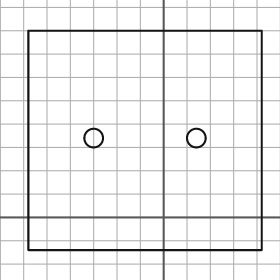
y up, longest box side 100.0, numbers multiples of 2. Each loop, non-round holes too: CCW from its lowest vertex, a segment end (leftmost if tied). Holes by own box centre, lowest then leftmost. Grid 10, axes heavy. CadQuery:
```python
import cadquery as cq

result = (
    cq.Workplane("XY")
    .moveTo(-58.0, -14.0)
    .lineTo(42.0, -14.0)
    .lineTo(42.0, 80.0)
    .lineTo(-58.0, 80.0)
    .close()
    .moveTo(-30.0, 34.0)
    .circle(4.0)
    .moveTo(14.0, 34.0)
    .circle(4.0)
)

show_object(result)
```